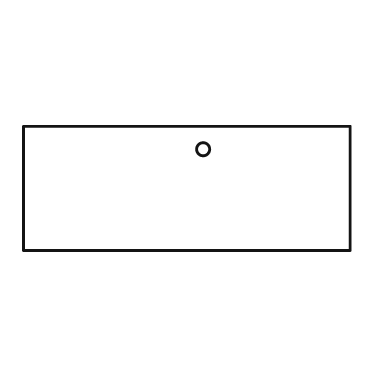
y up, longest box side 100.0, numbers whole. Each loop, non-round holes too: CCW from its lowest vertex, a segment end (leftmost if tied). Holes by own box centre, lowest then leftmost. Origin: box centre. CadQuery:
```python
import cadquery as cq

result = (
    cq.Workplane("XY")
    .moveTo(-50.0, -19.0)
    .lineTo(50.0, -19.0)
    .lineTo(50.0, 19.0)
    .lineTo(-50.0, 19.0)
    .close()
    .moveTo(5.0, 12.0)
    .circle(2.0)
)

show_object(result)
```